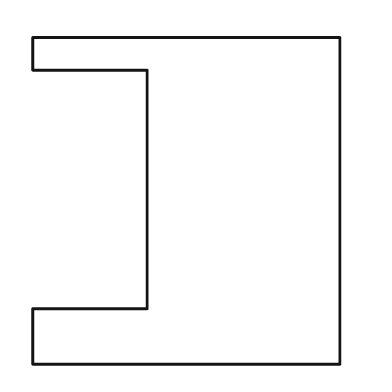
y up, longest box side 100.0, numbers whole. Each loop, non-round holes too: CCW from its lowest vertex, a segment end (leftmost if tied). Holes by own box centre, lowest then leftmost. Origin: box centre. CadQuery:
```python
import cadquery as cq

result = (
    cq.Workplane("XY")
    .moveTo(-47.0, -50.0)
    .lineTo(47.0, -50.0)
    .lineTo(47.0, 50.0)
    .lineTo(-47.0, 50.0)
    .lineTo(-47.0, 40.0)
    .lineTo(-12.0, 40.0)
    .lineTo(-12.0, -33.0)
    .lineTo(-47.0, -33.0)
    .close()
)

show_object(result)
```